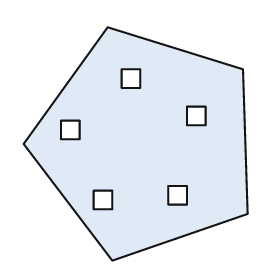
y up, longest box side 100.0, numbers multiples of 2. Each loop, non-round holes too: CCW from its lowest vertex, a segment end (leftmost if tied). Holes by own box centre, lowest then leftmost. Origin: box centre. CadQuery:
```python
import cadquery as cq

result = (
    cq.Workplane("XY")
    .moveTo(-10.0, -50.0)
    .lineTo(48.0, -30.0)
    .lineTo(46.0, 32.0)
    .lineTo(-12.0, 50.0)
    .lineTo(-48.0, 0.0)
    .close()
    .moveTo(-18.0, -28.0)
    .lineTo(-10.0, -28.0)
    .lineTo(-10.0, -20.0)
    .lineTo(-18.0, -20.0)
    .close()
    .moveTo(14.0, -26.0)
    .lineTo(22.0, -26.0)
    .lineTo(22.0, -18.0)
    .lineTo(14.0, -18.0)
    .close()
    .moveTo(-32.0, 2.0)
    .lineTo(-24.0, 2.0)
    .lineTo(-24.0, 10.0)
    .lineTo(-32.0, 10.0)
    .close()
    .moveTo(22.0, 8.0)
    .lineTo(30.0, 8.0)
    .lineTo(30.0, 16.0)
    .lineTo(22.0, 16.0)
    .close()
    .moveTo(-6.0, 24.0)
    .lineTo(2.0, 24.0)
    .lineTo(2.0, 32.0)
    .lineTo(-6.0, 32.0)
    .close()
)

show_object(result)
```